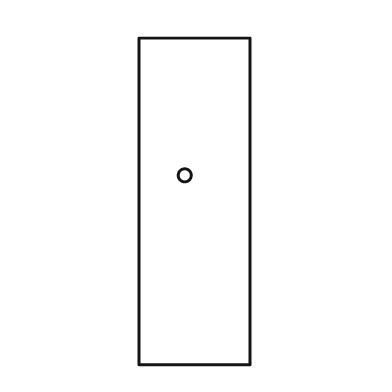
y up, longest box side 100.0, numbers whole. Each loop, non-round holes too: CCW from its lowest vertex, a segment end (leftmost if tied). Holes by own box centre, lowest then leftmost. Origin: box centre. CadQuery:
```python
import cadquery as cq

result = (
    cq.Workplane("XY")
    .moveTo(-17.0, -50.0)
    .lineTo(17.0, -50.0)
    .lineTo(17.0, 50.0)
    .lineTo(-17.0, 50.0)
    .close()
    .moveTo(-3.0, 8.0)
    .circle(2.0)
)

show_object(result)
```